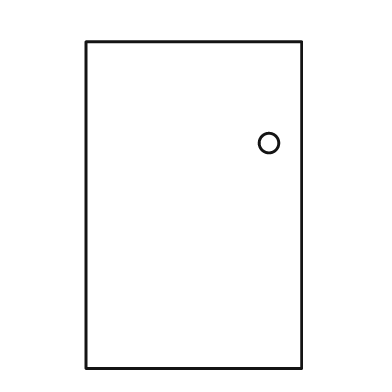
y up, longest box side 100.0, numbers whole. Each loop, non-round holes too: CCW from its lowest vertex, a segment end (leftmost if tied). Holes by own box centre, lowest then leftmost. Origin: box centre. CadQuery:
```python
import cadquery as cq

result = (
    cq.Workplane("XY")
    .moveTo(-33.0, -50.0)
    .lineTo(33.0, -50.0)
    .lineTo(33.0, 50.0)
    .lineTo(-33.0, 50.0)
    .close()
    .moveTo(23.0, 19.0)
    .circle(3.0)
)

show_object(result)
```